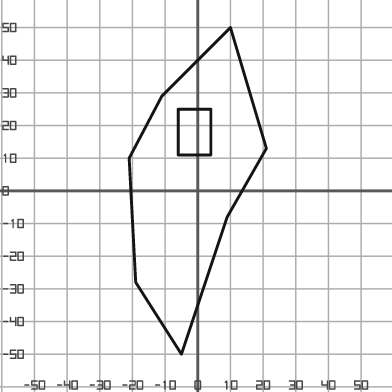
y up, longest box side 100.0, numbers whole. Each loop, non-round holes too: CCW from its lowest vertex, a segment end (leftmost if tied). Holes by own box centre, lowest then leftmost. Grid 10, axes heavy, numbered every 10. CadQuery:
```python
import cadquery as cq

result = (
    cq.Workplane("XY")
    .moveTo(-5.0, -50.0)
    .lineTo(9.0, -8.0)
    .lineTo(21.0, 13.0)
    .lineTo(10.0, 50.0)
    .lineTo(-11.0, 29.0)
    .lineTo(-21.0, 10.0)
    .lineTo(-19.0, -28.0)
    .close()
    .moveTo(-6.0, 11.0)
    .lineTo(4.0, 11.0)
    .lineTo(4.0, 25.0)
    .lineTo(-6.0, 25.0)
    .close()
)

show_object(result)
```